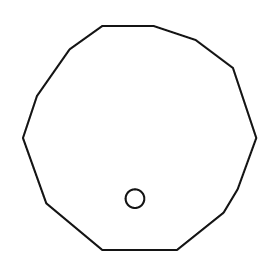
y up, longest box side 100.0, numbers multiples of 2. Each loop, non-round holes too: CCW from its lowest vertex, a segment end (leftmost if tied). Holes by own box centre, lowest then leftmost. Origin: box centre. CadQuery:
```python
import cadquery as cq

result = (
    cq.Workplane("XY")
    .moveTo(-16.0, -48.0)
    .lineTo(16.0, -48.0)
    .lineTo(36.0, -32.0)
    .lineTo(42.0, -22.0)
    .lineTo(50.0, 0.0)
    .lineTo(40.0, 30.0)
    .lineTo(24.0, 42.0)
    .lineTo(6.0, 48.0)
    .lineTo(-16.0, 48.0)
    .lineTo(-30.0, 38.0)
    .lineTo(-44.0, 18.0)
    .lineTo(-50.0, 0.0)
    .lineTo(-40.0, -28.0)
    .close()
    .moveTo(-2.0, -26.0)
    .circle(4.0)
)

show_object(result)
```